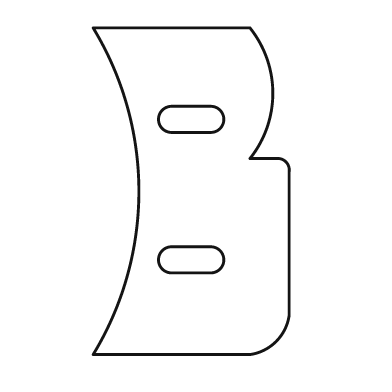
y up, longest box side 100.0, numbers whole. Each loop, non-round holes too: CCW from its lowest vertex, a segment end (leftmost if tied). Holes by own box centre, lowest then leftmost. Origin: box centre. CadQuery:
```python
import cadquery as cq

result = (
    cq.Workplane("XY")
    .moveTo(-30.0, -50.0)
    .lineTo(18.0, -50.0)
    .threePointArc((26.0, -46.0), (30.0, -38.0))
    .lineTo(30.0, 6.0)
    .threePointArc((29.0, 9.0), (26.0, 10.0))
    .lineTo(18.0, 10.0)
    .threePointArc((25.0, 30.0), (18.0, 50.0))
    .lineTo(-30.0, 50.0)
    .threePointArc((-16.0, 0.0), (-30.0, -50.0))
    .close()
    .moveTo(-6.0, -25.0)
    .lineTo(6.0, -25.0)
    .threePointArc((10.0, -21.0), (6.0, -17.0))
    .lineTo(-6.0, -17.0)
    .threePointArc((-10.0, -21.0), (-6.0, -25.0))
    .close()
    .moveTo(-6.0, 18.0)
    .lineTo(6.0, 18.0)
    .threePointArc((10.0, 22.0), (6.0, 26.0))
    .lineTo(-6.0, 26.0)
    .threePointArc((-10.0, 22.0), (-6.0, 18.0))
    .close()
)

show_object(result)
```